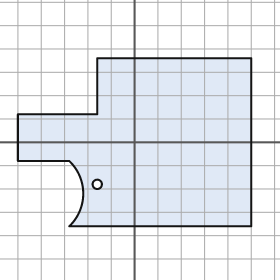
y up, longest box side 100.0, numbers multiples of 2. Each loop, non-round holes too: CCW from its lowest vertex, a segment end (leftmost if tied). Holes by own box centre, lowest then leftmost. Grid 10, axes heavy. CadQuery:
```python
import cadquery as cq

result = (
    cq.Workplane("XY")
    .moveTo(-28.0, -36.0)
    .lineTo(50.0, -36.0)
    .lineTo(50.0, 36.0)
    .lineTo(-16.0, 36.0)
    .lineTo(-16.0, 12.0)
    .lineTo(-50.0, 12.0)
    .lineTo(-50.0, -8.0)
    .lineTo(-28.0, -8.0)
    .threePointArc((-22.0, -22.0), (-28.0, -36.0))
    .close()
    .moveTo(-16.0, -18.0)
    .circle(2.0)
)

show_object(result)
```